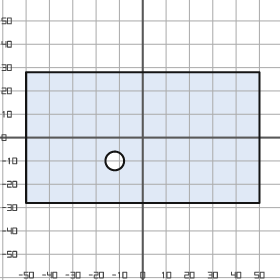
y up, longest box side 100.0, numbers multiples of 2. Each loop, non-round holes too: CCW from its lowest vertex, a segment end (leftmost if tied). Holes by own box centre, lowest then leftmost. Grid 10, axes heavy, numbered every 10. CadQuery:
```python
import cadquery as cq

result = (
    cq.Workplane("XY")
    .moveTo(-50.0, -28.0)
    .lineTo(50.0, -28.0)
    .lineTo(50.0, 28.0)
    .lineTo(-50.0, 28.0)
    .close()
    .moveTo(-12.0, -10.0)
    .circle(4.0)
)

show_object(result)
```